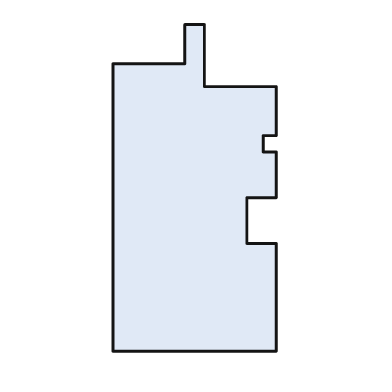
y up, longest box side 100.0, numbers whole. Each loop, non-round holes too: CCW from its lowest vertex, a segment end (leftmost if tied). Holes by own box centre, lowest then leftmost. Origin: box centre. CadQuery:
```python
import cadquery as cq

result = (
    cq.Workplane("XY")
    .moveTo(-25.0, -50.0)
    .lineTo(25.0, -50.0)
    .lineTo(25.0, -17.0)
    .lineTo(16.0, -17.0)
    .lineTo(16.0, -3.0)
    .lineTo(25.0, -3.0)
    .lineTo(25.0, 11.0)
    .lineTo(21.0, 11.0)
    .lineTo(21.0, 16.0)
    .lineTo(25.0, 16.0)
    .lineTo(25.0, 31.0)
    .lineTo(3.0, 31.0)
    .lineTo(3.0, 50.0)
    .lineTo(-3.0, 50.0)
    .lineTo(-3.0, 38.0)
    .lineTo(-25.0, 38.0)
    .close()
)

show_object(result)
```